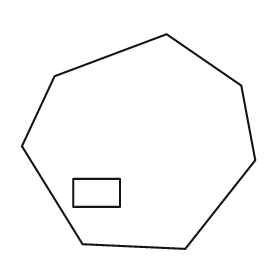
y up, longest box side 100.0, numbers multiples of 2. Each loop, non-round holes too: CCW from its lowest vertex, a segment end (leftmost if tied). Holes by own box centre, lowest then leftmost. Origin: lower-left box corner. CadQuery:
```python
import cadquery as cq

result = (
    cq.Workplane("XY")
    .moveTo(70.0, 0.0)
    .lineTo(100.0, 38.0)
    .lineTo(94.0, 70.0)
    .lineTo(62.0, 92.0)
    .lineTo(14.0, 74.0)
    .lineTo(0.0, 44.0)
    .lineTo(26.0, 2.0)
    .close()
    .moveTo(22.0, 18.0)
    .lineTo(42.0, 18.0)
    .lineTo(42.0, 30.0)
    .lineTo(22.0, 30.0)
    .close()
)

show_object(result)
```